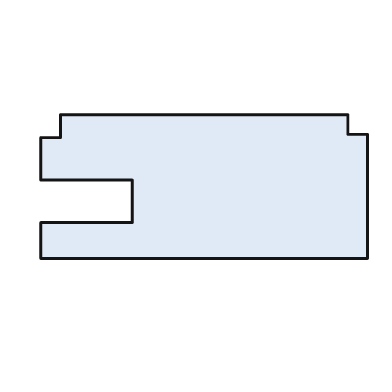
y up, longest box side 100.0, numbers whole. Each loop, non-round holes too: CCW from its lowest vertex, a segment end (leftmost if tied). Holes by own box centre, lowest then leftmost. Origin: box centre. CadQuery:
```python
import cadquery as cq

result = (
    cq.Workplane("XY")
    .moveTo(-50.0, -22.0)
    .lineTo(50.0, -22.0)
    .lineTo(50.0, 16.0)
    .lineTo(44.0, 16.0)
    .lineTo(44.0, 22.0)
    .lineTo(-44.0, 22.0)
    .lineTo(-44.0, 15.0)
    .lineTo(-50.0, 15.0)
    .lineTo(-50.0, 2.0)
    .lineTo(-22.0, 2.0)
    .lineTo(-22.0, -11.0)
    .lineTo(-50.0, -11.0)
    .close()
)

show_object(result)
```